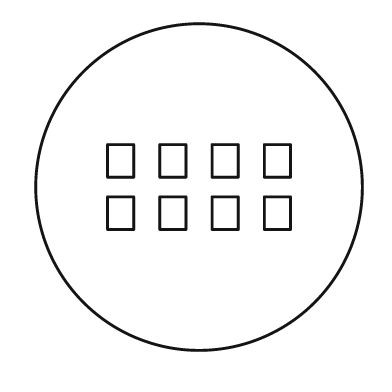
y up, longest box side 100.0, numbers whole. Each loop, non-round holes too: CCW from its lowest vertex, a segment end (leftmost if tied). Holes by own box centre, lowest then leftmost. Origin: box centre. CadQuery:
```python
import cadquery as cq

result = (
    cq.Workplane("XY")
    .moveTo(0.0, 0.0)
    .circle(50.0)
    .moveTo(-28.0, -13.0)
    .lineTo(-20.0, -13.0)
    .lineTo(-20.0, -3.0)
    .lineTo(-28.0, -3.0)
    .close()
    .moveTo(-12.0, -13.0)
    .lineTo(-4.0, -13.0)
    .lineTo(-4.0, -3.0)
    .lineTo(-12.0, -3.0)
    .close()
    .moveTo(4.0, -13.0)
    .lineTo(12.0, -13.0)
    .lineTo(12.0, -3.0)
    .lineTo(4.0, -3.0)
    .close()
    .moveTo(20.0, -13.0)
    .lineTo(28.0, -13.0)
    .lineTo(28.0, -3.0)
    .lineTo(20.0, -3.0)
    .close()
    .moveTo(-28.0, 3.0)
    .lineTo(-20.0, 3.0)
    .lineTo(-20.0, 13.0)
    .lineTo(-28.0, 13.0)
    .close()
    .moveTo(-12.0, 3.0)
    .lineTo(-4.0, 3.0)
    .lineTo(-4.0, 13.0)
    .lineTo(-12.0, 13.0)
    .close()
    .moveTo(4.0, 3.0)
    .lineTo(12.0, 3.0)
    .lineTo(12.0, 13.0)
    .lineTo(4.0, 13.0)
    .close()
    .moveTo(20.0, 3.0)
    .lineTo(28.0, 3.0)
    .lineTo(28.0, 13.0)
    .lineTo(20.0, 13.0)
    .close()
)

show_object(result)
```